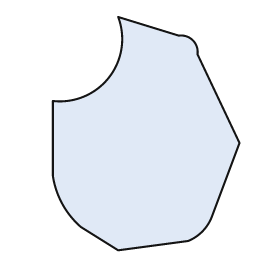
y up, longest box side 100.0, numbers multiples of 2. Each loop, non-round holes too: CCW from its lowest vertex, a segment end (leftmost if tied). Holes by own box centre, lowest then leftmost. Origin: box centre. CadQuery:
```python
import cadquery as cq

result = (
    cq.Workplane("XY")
    .moveTo(-12.0, -50.0)
    .lineTo(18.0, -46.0)
    .threePointArc((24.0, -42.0), (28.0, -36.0))
    .lineTo(40.0, -4.0)
    .lineTo(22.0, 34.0)
    .threePointArc((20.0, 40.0), (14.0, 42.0))
    .lineTo(-12.0, 50.0)
    .threePointArc((-16.0, 24.0), (-40.0, 14.0))
    .lineTo(-40.0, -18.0)
    .threePointArc((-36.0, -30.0), (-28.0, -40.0))
    .close()
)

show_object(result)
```